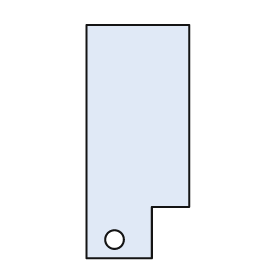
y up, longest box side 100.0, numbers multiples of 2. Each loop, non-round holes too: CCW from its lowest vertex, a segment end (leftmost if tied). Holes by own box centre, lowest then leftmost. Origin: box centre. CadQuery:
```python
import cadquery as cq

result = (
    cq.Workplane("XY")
    .moveTo(-22.0, -50.0)
    .lineTo(6.0, -50.0)
    .lineTo(6.0, -28.0)
    .lineTo(22.0, -28.0)
    .lineTo(22.0, 50.0)
    .lineTo(-22.0, 50.0)
    .close()
    .moveTo(-10.0, -42.0)
    .circle(4.0)
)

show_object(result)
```